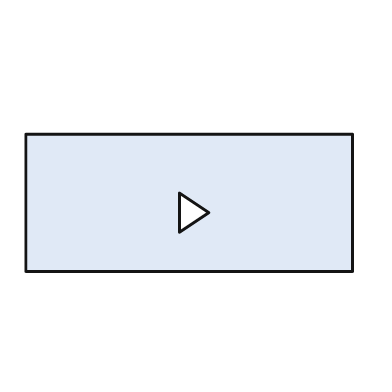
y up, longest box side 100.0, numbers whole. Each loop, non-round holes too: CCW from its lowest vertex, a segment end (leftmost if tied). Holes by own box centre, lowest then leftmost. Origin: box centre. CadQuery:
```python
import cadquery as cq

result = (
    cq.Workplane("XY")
    .moveTo(-50.0, -21.0)
    .lineTo(50.0, -21.0)
    .lineTo(50.0, 21.0)
    .lineTo(-50.0, 21.0)
    .close()
    .moveTo(-3.0, -9.0)
    .lineTo(6.0, -3.0)
    .lineTo(-3.0, 3.0)
    .close()
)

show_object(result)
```